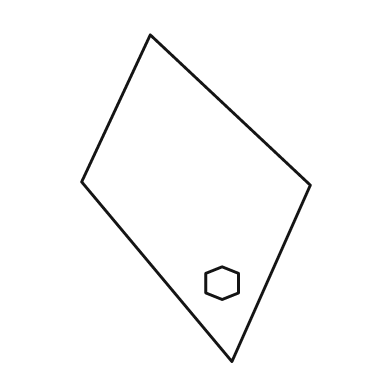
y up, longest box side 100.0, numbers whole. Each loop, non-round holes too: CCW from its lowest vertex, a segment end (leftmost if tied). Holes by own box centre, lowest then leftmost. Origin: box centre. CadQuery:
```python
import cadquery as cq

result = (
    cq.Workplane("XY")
    .moveTo(11.0, -50.0)
    .lineTo(35.0, 4.0)
    .lineTo(-14.0, 50.0)
    .lineTo(-35.0, 5.0)
    .close()
    .moveTo(8.0, -31.0)
    .lineTo(13.0, -29.0)
    .lineTo(13.0, -23.0)
    .lineTo(8.0, -21.0)
    .lineTo(3.0, -23.0)
    .lineTo(3.0, -29.0)
    .close()
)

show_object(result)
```